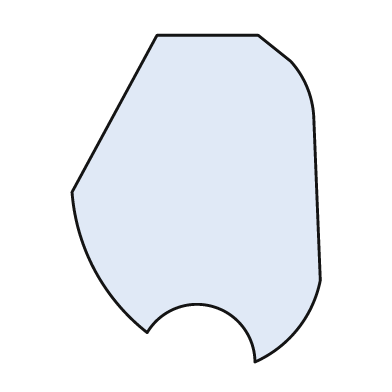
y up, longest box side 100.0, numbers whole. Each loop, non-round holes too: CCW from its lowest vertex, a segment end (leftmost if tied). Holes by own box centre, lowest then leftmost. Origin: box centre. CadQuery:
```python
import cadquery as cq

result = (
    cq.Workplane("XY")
    .moveTo(18.0, -50.0)
    .threePointArc((31.0, -40.0), (38.0, -25.0))
    .lineTo(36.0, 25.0)
    .threePointArc((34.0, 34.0), (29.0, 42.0))
    .lineTo(19.0, 50.0)
    .lineTo(-12.0, 50.0)
    .lineTo(-38.0, 2.0)
    .threePointArc((-31.0, -22.0), (-15.0, -41.0))
    .threePointArc((5.0, -33.0), (18.0, -50.0))
    .close()
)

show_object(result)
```